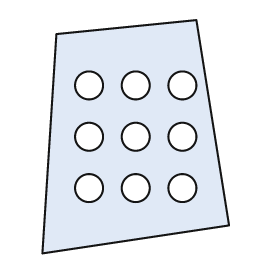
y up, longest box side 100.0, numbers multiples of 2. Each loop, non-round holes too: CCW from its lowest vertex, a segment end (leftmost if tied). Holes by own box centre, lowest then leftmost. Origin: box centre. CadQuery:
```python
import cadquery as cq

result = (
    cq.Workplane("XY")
    .moveTo(-40.0, -50.0)
    .lineTo(40.0, -38.0)
    .lineTo(26.0, 50.0)
    .lineTo(-34.0, 44.0)
    .close()
    .moveTo(-20.0, -22.0)
    .circle(6.0)
    .moveTo(0.0, -22.0)
    .circle(6.0)
    .moveTo(20.0, -22.0)
    .circle(6.0)
    .moveTo(-20.0, 0.0)
    .circle(6.0)
    .moveTo(0.0, 0.0)
    .circle(6.0)
    .moveTo(20.0, 0.0)
    .circle(6.0)
    .moveTo(-20.0, 22.0)
    .circle(6.0)
    .moveTo(0.0, 22.0)
    .circle(6.0)
    .moveTo(20.0, 22.0)
    .circle(6.0)
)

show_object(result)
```